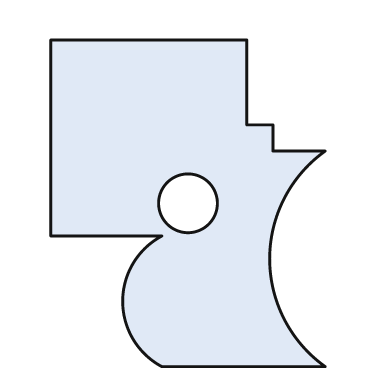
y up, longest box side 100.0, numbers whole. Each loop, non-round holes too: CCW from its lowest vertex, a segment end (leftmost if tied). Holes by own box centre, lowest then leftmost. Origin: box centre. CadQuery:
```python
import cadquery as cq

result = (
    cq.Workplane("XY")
    .moveTo(-8.0, -50.0)
    .lineTo(42.0, -50.0)
    .threePointArc((25.0, -17.0), (42.0, 16.0))
    .lineTo(26.0, 16.0)
    .lineTo(26.0, 24.0)
    .lineTo(18.0, 24.0)
    .lineTo(18.0, 50.0)
    .lineTo(-42.0, 50.0)
    .lineTo(-42.0, -10.0)
    .lineTo(-8.0, -10.0)
    .threePointArc((-20.0, -30.0), (-8.0, -50.0))
    .close()
    .moveTo(0.0, 0.0)
    .circle(9.0)
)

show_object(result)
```